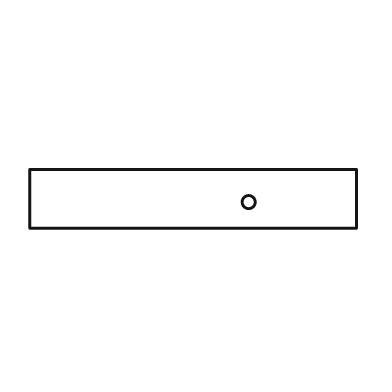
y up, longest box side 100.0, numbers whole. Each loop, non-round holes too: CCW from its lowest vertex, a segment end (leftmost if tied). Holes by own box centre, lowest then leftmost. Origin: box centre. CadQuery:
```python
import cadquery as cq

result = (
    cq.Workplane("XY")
    .moveTo(-50.0, -9.0)
    .lineTo(50.0, -9.0)
    .lineTo(50.0, 9.0)
    .lineTo(-50.0, 9.0)
    .close()
    .moveTo(17.0, -1.0)
    .circle(2.0)
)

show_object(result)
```